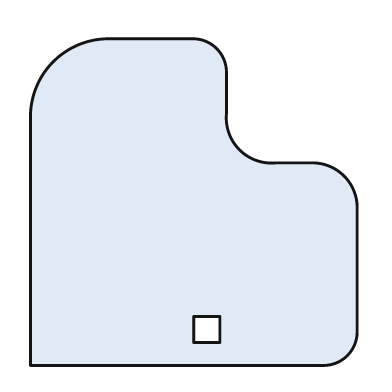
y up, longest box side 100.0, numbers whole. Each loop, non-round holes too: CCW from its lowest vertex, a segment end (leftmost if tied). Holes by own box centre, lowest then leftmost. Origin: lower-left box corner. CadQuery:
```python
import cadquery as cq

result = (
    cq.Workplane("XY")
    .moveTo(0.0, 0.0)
    .lineTo(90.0, 0.0)
    .threePointArc((97.0, 3.0), (100.0, 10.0))
    .lineTo(100.0, 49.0)
    .threePointArc((96.0, 58.0), (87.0, 62.0))
    .lineTo(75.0, 62.0)
    .threePointArc((64.0, 66.0), (60.0, 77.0))
    .lineTo(60.0, 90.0)
    .threePointArc((57.0, 97.0), (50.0, 100.0))
    .lineTo(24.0, 100.0)
    .threePointArc((7.0, 93.0), (0.0, 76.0))
    .close()
    .moveTo(50.0, 7.0)
    .lineTo(58.0, 7.0)
    .lineTo(58.0, 15.0)
    .lineTo(50.0, 15.0)
    .close()
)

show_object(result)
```